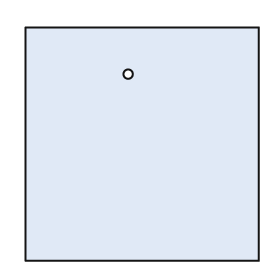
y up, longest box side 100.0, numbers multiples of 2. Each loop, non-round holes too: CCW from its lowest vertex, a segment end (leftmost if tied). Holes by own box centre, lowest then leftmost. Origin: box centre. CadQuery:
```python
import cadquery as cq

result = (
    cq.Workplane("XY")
    .moveTo(-50.0, -50.0)
    .lineTo(50.0, -50.0)
    .lineTo(50.0, 50.0)
    .lineTo(-50.0, 50.0)
    .close()
    .moveTo(-6.0, 30.0)
    .circle(2.0)
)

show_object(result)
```